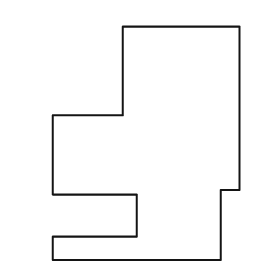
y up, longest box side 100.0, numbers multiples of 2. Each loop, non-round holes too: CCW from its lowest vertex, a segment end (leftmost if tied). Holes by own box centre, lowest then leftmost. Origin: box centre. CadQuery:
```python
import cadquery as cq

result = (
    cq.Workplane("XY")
    .moveTo(-40.0, -50.0)
    .lineTo(32.0, -50.0)
    .lineTo(32.0, -20.0)
    .lineTo(40.0, -20.0)
    .lineTo(40.0, 50.0)
    .lineTo(-10.0, 50.0)
    .lineTo(-10.0, 12.0)
    .lineTo(-40.0, 12.0)
    .lineTo(-40.0, -22.0)
    .lineTo(-4.0, -22.0)
    .lineTo(-4.0, -40.0)
    .lineTo(-40.0, -40.0)
    .close()
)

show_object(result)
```